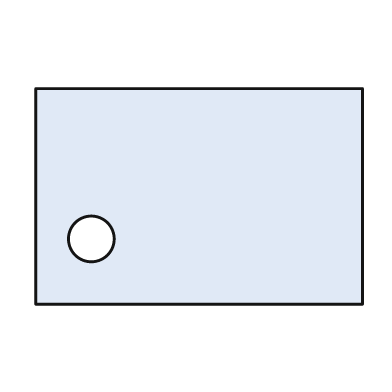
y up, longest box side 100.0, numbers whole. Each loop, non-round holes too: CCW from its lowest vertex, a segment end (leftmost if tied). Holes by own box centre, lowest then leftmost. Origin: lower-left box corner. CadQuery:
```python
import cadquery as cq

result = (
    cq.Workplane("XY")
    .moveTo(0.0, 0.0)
    .lineTo(100.0, 0.0)
    .lineTo(100.0, 66.0)
    .lineTo(0.0, 66.0)
    .close()
    .moveTo(17.0, 20.0)
    .circle(7.0)
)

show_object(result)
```